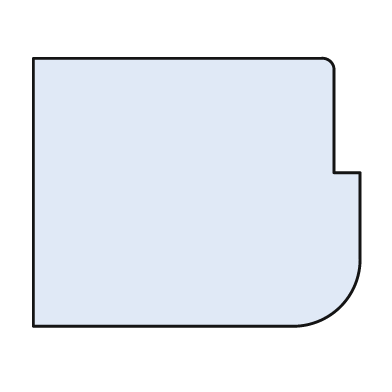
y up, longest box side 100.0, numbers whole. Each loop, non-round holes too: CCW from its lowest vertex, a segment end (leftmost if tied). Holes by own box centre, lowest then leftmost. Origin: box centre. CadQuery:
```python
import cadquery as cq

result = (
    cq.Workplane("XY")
    .moveTo(-50.0, -41.0)
    .lineTo(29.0, -41.0)
    .threePointArc((44.0, -35.0), (50.0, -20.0))
    .lineTo(50.0, 6.0)
    .lineTo(42.0, 6.0)
    .lineTo(42.0, 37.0)
    .threePointArc((41.0, 40.0), (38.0, 41.0))
    .lineTo(-50.0, 41.0)
    .close()
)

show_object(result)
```